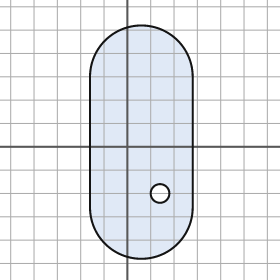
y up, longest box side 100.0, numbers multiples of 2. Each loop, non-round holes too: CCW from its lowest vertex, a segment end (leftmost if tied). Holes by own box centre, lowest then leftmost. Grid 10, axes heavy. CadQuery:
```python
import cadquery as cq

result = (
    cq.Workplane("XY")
    .moveTo(-16.0, -26.0)
    .threePointArc((6.0, -48.0), (28.0, -26.0))
    .lineTo(28.0, 30.0)
    .threePointArc((6.0, 52.0), (-16.0, 30.0))
    .close()
    .moveTo(14.0, -20.0)
    .circle(4.0)
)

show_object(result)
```